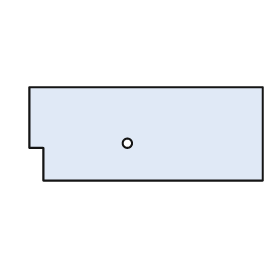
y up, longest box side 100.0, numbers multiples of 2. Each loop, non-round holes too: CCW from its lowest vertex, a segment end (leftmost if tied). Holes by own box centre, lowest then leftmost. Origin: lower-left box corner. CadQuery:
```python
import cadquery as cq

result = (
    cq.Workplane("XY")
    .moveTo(6.0, 0.0)
    .lineTo(100.0, 0.0)
    .lineTo(100.0, 40.0)
    .lineTo(0.0, 40.0)
    .lineTo(0.0, 14.0)
    .lineTo(6.0, 14.0)
    .close()
    .moveTo(42.0, 16.0)
    .circle(2.0)
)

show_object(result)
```